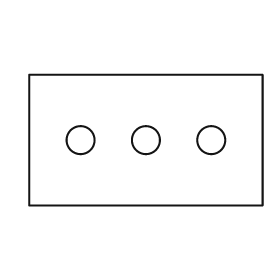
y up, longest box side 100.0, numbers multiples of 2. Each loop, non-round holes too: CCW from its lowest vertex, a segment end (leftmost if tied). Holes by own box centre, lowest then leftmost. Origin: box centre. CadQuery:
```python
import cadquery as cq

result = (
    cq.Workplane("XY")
    .moveTo(-50.0, -28.0)
    .lineTo(50.0, -28.0)
    .lineTo(50.0, 28.0)
    .lineTo(-50.0, 28.0)
    .close()
    .moveTo(-28.0, 0.0)
    .circle(6.0)
    .moveTo(0.0, 0.0)
    .circle(6.0)
    .moveTo(28.0, 0.0)
    .circle(6.0)
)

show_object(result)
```